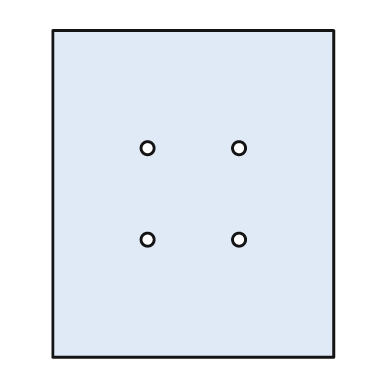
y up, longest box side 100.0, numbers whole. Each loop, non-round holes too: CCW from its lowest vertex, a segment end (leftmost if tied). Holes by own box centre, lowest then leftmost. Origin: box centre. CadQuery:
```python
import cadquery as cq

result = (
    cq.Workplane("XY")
    .moveTo(-43.0, -50.0)
    .lineTo(43.0, -50.0)
    .lineTo(43.0, 50.0)
    .lineTo(-43.0, 50.0)
    .close()
    .moveTo(-14.0, -14.0)
    .circle(2.0)
    .moveTo(14.0, -14.0)
    .circle(2.0)
    .moveTo(-14.0, 14.0)
    .circle(2.0)
    .moveTo(14.0, 14.0)
    .circle(2.0)
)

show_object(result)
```